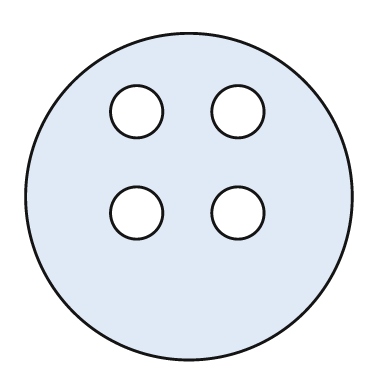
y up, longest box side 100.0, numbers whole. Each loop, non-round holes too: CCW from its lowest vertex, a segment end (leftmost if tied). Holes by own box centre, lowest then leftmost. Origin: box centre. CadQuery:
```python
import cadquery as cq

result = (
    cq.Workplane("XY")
    .moveTo(0.0, 0.0)
    .circle(50.0)
    .moveTo(-16.0, -5.0)
    .circle(8.0)
    .moveTo(15.0, -5.0)
    .circle(8.0)
    .moveTo(-16.0, 26.0)
    .circle(8.0)
    .moveTo(15.0, 26.0)
    .circle(8.0)
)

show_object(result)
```